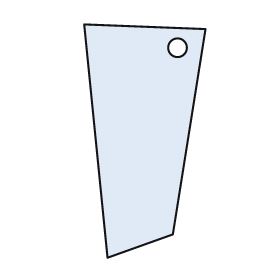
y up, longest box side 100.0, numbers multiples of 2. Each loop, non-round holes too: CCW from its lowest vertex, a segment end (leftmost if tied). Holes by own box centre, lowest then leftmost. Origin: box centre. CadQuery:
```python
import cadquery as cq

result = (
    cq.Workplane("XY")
    .moveTo(-16.0, -50.0)
    .lineTo(12.0, -40.0)
    .lineTo(26.0, 48.0)
    .lineTo(-26.0, 50.0)
    .close()
    .moveTo(14.0, 40.0)
    .circle(4.0)
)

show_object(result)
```